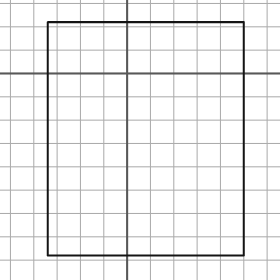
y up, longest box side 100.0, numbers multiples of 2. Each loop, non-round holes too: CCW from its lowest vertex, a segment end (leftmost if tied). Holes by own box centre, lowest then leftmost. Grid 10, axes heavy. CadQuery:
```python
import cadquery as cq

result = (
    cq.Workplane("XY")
    .moveTo(-34.0, -78.0)
    .lineTo(50.0, -78.0)
    .lineTo(50.0, 22.0)
    .lineTo(-34.0, 22.0)
    .close()
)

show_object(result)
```